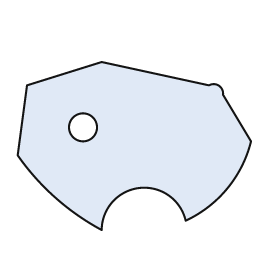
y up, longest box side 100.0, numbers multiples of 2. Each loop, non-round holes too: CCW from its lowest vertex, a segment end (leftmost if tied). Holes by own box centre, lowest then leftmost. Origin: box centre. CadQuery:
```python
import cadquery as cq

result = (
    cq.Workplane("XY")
    .moveTo(-14.0, -36.0)
    .threePointArc((2.0, -18.0), (22.0, -32.0))
    .threePointArc((40.0, -18.0), (50.0, 2.0))
    .lineTo(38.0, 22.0)
    .threePointArc((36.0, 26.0), (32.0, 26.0))
    .lineTo(-14.0, 36.0)
    .lineTo(-46.0, 26.0)
    .lineTo(-50.0, -4.0)
    .threePointArc((-34.0, -22.0), (-14.0, -36.0))
    .close()
    .moveTo(-22.0, 8.0)
    .circle(6.0)
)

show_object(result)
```